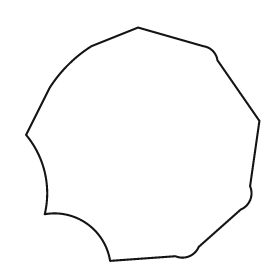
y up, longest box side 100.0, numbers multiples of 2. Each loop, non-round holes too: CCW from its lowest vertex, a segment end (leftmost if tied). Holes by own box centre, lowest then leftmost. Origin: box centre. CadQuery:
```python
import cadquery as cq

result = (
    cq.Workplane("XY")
    .moveTo(-14.0, -50.0)
    .lineTo(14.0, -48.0)
    .threePointArc((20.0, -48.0), (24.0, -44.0))
    .lineTo(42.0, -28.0)
    .threePointArc((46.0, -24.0), (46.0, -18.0))
    .lineTo(50.0, 10.0)
    .lineTo(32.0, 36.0)
    .threePointArc((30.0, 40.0), (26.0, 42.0))
    .lineTo(-2.0, 50.0)
    .lineTo(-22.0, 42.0)
    .threePointArc((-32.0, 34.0), (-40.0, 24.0))
    .lineTo(-50.0, 4.0)
    .threePointArc((-42.0, -12.0), (-42.0, -30.0))
    .threePointArc((-24.0, -34.0), (-14.0, -50.0))
    .close()
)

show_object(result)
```